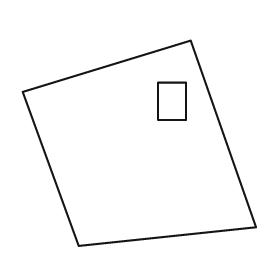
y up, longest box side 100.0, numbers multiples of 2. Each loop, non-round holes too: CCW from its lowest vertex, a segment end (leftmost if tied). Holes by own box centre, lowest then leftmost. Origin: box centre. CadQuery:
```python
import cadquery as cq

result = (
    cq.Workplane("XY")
    .moveTo(-26.0, -44.0)
    .lineTo(50.0, -36.0)
    .lineTo(22.0, 44.0)
    .lineTo(-50.0, 22.0)
    .close()
    .moveTo(8.0, 10.0)
    .lineTo(20.0, 10.0)
    .lineTo(20.0, 26.0)
    .lineTo(8.0, 26.0)
    .close()
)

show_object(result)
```